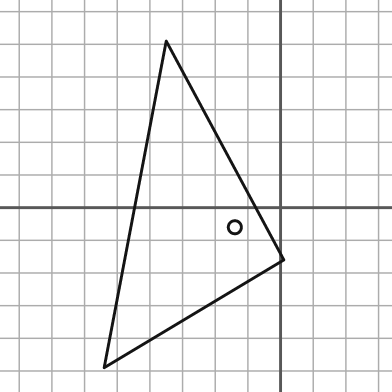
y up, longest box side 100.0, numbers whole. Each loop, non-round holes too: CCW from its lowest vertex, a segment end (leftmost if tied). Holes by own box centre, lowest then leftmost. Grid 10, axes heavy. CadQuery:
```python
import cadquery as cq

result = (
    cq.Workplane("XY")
    .moveTo(-54.0, -49.0)
    .lineTo(1.0, -16.0)
    .lineTo(-35.0, 51.0)
    .close()
    .moveTo(-14.0, -6.0)
    .circle(2.0)
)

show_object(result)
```